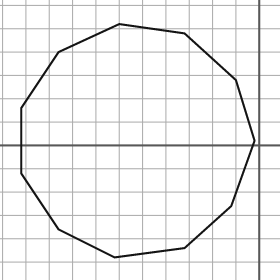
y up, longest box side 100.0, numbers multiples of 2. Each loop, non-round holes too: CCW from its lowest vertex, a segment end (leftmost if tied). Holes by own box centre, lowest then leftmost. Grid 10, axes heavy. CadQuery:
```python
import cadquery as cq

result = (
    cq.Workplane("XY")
    .moveTo(-62.0, -48.0)
    .lineTo(-32.0, -44.0)
    .lineTo(-12.0, -26.0)
    .lineTo(-2.0, 2.0)
    .lineTo(-10.0, 28.0)
    .lineTo(-32.0, 48.0)
    .lineTo(-60.0, 52.0)
    .lineTo(-86.0, 40.0)
    .lineTo(-102.0, 16.0)
    .lineTo(-102.0, -12.0)
    .lineTo(-86.0, -36.0)
    .close()
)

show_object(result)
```